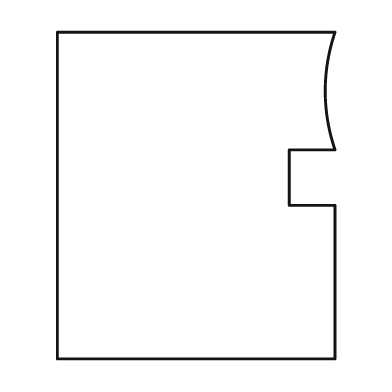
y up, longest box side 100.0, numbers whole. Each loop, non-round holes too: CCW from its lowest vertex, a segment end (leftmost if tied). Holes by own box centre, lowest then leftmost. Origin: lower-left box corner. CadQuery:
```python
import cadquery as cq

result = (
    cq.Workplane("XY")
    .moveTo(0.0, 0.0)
    .lineTo(85.0, 0.0)
    .lineTo(85.0, 47.0)
    .lineTo(71.0, 47.0)
    .lineTo(71.0, 64.0)
    .lineTo(85.0, 64.0)
    .threePointArc((82.0, 82.0), (85.0, 100.0))
    .lineTo(0.0, 100.0)
    .close()
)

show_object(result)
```